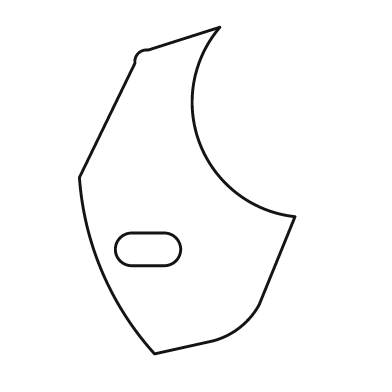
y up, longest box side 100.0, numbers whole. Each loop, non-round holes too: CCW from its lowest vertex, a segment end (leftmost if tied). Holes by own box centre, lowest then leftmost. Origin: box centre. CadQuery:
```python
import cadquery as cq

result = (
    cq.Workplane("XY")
    .moveTo(-10.0, -50.0)
    .lineTo(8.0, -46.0)
    .threePointArc((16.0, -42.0), (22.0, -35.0))
    .lineTo(33.0, -8.0)
    .threePointArc((4.0, 14.0), (10.0, 50.0))
    .lineTo(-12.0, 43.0)
    .threePointArc((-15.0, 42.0), (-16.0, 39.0))
    .lineTo(-33.0, 4.0)
    .threePointArc((-26.0, -25.0), (-10.0, -50.0))
    .close()
    .moveTo(-17.0, -23.0)
    .lineTo(-7.0, -23.0)
    .threePointArc((-2.0, -18.0), (-7.0, -13.0))
    .lineTo(-17.0, -13.0)
    .threePointArc((-22.0, -18.0), (-17.0, -23.0))
    .close()
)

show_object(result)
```